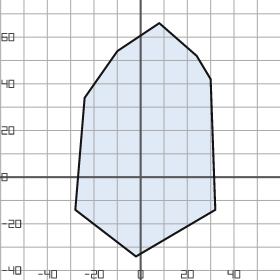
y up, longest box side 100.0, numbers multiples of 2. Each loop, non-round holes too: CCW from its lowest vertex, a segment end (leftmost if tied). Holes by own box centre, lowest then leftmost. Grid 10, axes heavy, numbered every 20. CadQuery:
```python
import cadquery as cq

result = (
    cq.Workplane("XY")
    .moveTo(-2.0, -34.0)
    .lineTo(32.0, -14.0)
    .lineTo(30.0, 42.0)
    .lineTo(24.0, 52.0)
    .lineTo(8.0, 66.0)
    .lineTo(-10.0, 54.0)
    .lineTo(-24.0, 34.0)
    .lineTo(-28.0, -14.0)
    .close()
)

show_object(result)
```